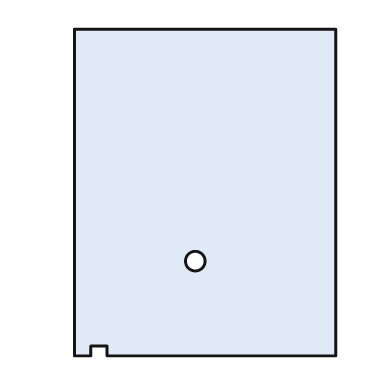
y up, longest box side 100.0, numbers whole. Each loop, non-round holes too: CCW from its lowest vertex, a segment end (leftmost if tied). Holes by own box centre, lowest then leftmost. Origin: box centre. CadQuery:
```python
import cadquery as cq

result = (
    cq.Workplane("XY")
    .moveTo(-40.0, -50.0)
    .lineTo(-35.0, -50.0)
    .lineTo(-35.0, -47.0)
    .lineTo(-30.0, -47.0)
    .lineTo(-30.0, -50.0)
    .lineTo(40.0, -50.0)
    .lineTo(40.0, 50.0)
    .lineTo(-40.0, 50.0)
    .close()
    .moveTo(-3.0, -21.0)
    .circle(3.0)
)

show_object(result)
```